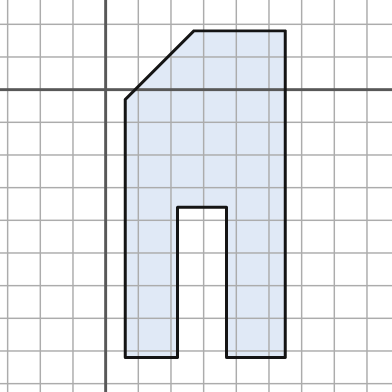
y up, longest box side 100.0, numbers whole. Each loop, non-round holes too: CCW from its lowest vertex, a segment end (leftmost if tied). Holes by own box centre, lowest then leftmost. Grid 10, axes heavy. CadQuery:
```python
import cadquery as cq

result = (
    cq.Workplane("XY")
    .moveTo(6.0, -82.0)
    .lineTo(22.0, -82.0)
    .lineTo(22.0, -36.0)
    .lineTo(37.0, -36.0)
    .lineTo(37.0, -82.0)
    .lineTo(55.0, -82.0)
    .lineTo(55.0, 18.0)
    .lineTo(27.0, 18.0)
    .lineTo(6.0, -3.0)
    .close()
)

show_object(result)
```